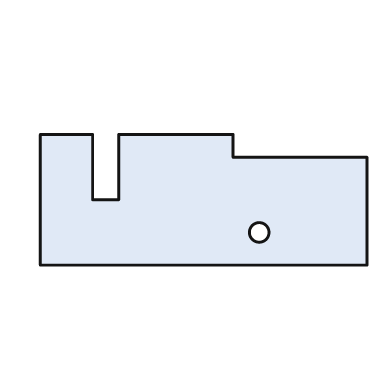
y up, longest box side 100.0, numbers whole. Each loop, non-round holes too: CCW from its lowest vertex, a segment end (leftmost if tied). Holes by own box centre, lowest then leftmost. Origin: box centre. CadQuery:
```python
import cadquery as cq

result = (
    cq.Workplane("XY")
    .moveTo(-50.0, -20.0)
    .lineTo(50.0, -20.0)
    .lineTo(50.0, 13.0)
    .lineTo(9.0, 13.0)
    .lineTo(9.0, 20.0)
    .lineTo(-26.0, 20.0)
    .lineTo(-26.0, 0.0)
    .lineTo(-34.0, 0.0)
    .lineTo(-34.0, 20.0)
    .lineTo(-50.0, 20.0)
    .close()
    .moveTo(17.0, -10.0)
    .circle(3.0)
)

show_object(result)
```